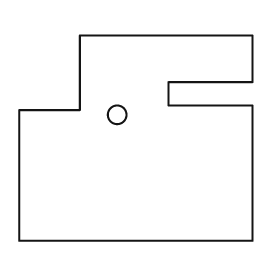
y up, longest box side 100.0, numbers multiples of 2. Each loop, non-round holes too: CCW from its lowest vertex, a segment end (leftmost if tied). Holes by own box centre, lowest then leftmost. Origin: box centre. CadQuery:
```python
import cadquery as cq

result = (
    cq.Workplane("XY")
    .moveTo(-50.0, -44.0)
    .lineTo(50.0, -44.0)
    .lineTo(50.0, 14.0)
    .lineTo(14.0, 14.0)
    .lineTo(14.0, 24.0)
    .lineTo(50.0, 24.0)
    .lineTo(50.0, 44.0)
    .lineTo(-24.0, 44.0)
    .lineTo(-24.0, 12.0)
    .lineTo(-50.0, 12.0)
    .close()
    .moveTo(-8.0, 10.0)
    .circle(4.0)
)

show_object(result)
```